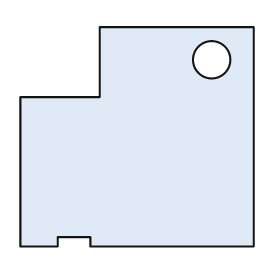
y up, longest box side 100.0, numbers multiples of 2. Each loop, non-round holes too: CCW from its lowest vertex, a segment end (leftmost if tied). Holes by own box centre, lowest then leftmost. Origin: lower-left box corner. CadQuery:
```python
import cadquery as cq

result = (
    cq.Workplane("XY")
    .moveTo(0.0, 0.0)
    .lineTo(16.0, 0.0)
    .lineTo(16.0, 4.0)
    .lineTo(30.0, 4.0)
    .lineTo(30.0, 0.0)
    .lineTo(100.0, 0.0)
    .lineTo(100.0, 94.0)
    .lineTo(34.0, 94.0)
    .lineTo(34.0, 64.0)
    .lineTo(0.0, 64.0)
    .close()
    .moveTo(82.0, 80.0)
    .circle(8.0)
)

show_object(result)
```